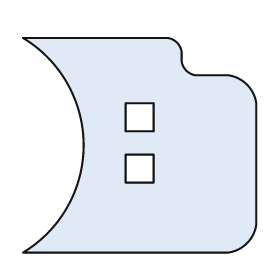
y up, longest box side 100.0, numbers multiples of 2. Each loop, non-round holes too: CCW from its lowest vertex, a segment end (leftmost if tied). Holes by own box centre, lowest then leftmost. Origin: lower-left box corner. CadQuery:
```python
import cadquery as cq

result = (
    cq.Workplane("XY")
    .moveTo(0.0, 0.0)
    .lineTo(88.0, 0.0)
    .threePointArc((96.0, 4.0), (100.0, 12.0))
    .lineTo(100.0, 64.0)
    .threePointArc((96.0, 72.0), (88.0, 76.0))
    .lineTo(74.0, 76.0)
    .threePointArc((70.0, 78.0), (68.0, 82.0))
    .lineTo(68.0, 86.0)
    .threePointArc((66.0, 90.0), (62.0, 92.0))
    .lineTo(0.0, 92.0)
    .threePointArc((26.0, 46.0), (0.0, 0.0))
    .close()
    .moveTo(44.0, 30.0)
    .lineTo(56.0, 30.0)
    .lineTo(56.0, 42.0)
    .lineTo(44.0, 42.0)
    .close()
    .moveTo(44.0, 52.0)
    .lineTo(56.0, 52.0)
    .lineTo(56.0, 64.0)
    .lineTo(44.0, 64.0)
    .close()
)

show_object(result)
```